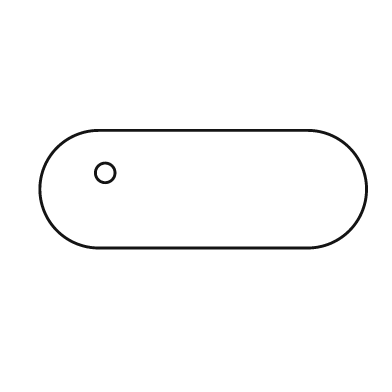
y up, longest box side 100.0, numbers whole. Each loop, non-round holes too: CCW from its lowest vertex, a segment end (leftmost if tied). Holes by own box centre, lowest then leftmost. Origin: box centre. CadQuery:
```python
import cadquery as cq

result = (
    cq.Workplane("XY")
    .moveTo(-32.0, -18.0)
    .lineTo(32.0, -18.0)
    .threePointArc((50.0, 0.0), (32.0, 18.0))
    .lineTo(-32.0, 18.0)
    .threePointArc((-50.0, 0.0), (-32.0, -18.0))
    .close()
    .moveTo(-30.0, 5.0)
    .circle(3.0)
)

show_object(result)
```